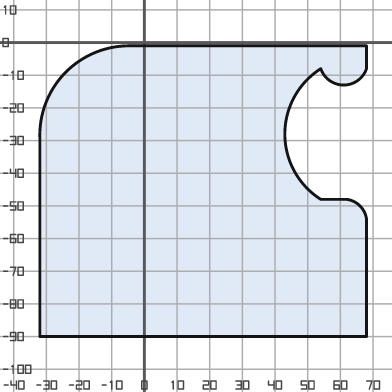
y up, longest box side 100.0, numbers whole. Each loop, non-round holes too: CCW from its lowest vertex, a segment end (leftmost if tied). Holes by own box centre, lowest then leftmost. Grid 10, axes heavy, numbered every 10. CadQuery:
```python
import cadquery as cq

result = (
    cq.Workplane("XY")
    .moveTo(-32.0, -90.0)
    .lineTo(68.0, -90.0)
    .lineTo(68.0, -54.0)
    .threePointArc((66.0, -50.0), (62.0, -48.0))
    .lineTo(54.0, -48.0)
    .threePointArc((43.0, -28.0), (54.0, -8.0))
    .threePointArc((61.0, -13.0), (68.0, -8.0))
    .lineTo(68.0, -1.0)
    .lineTo(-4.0, -1.0)
    .threePointArc((-24.0, -9.0), (-32.0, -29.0))
    .close()
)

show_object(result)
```